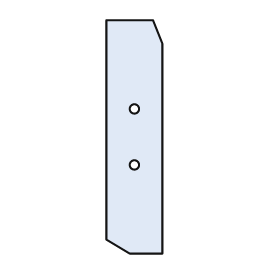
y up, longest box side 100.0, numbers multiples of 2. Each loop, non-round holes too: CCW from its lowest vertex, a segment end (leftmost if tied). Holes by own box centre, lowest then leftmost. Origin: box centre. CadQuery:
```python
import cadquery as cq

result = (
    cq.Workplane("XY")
    .moveTo(-2.0, -50.0)
    .lineTo(12.0, -50.0)
    .lineTo(12.0, 40.0)
    .lineTo(8.0, 50.0)
    .lineTo(-12.0, 50.0)
    .lineTo(-12.0, -44.0)
    .close()
    .moveTo(0.0, -12.0)
    .circle(2.0)
    .moveTo(0.0, 12.0)
    .circle(2.0)
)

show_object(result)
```